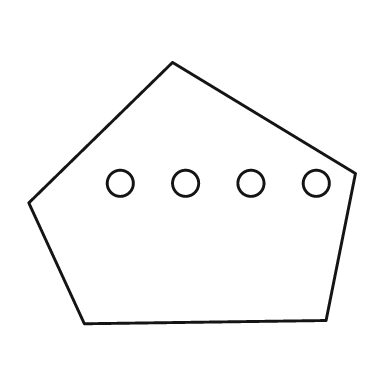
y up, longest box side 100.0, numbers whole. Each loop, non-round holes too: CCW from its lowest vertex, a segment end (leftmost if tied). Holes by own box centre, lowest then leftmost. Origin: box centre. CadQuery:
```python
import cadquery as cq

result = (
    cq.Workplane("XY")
    .moveTo(-33.0, -40.0)
    .lineTo(41.0, -39.0)
    .lineTo(50.0, 6.0)
    .lineTo(-6.0, 40.0)
    .lineTo(-50.0, -3.0)
    .close()
    .moveTo(-22.0, 3.0)
    .circle(4.0)
    .moveTo(-2.0, 3.0)
    .circle(4.0)
    .moveTo(18.0, 3.0)
    .circle(4.0)
    .moveTo(38.0, 3.0)
    .circle(4.0)
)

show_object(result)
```